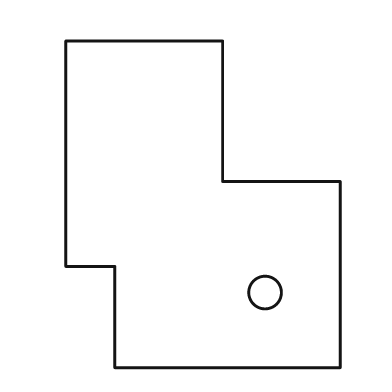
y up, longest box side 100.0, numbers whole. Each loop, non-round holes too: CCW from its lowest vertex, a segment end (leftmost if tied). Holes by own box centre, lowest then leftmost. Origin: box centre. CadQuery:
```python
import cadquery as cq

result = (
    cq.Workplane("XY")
    .moveTo(-27.0, -50.0)
    .lineTo(42.0, -50.0)
    .lineTo(42.0, 7.0)
    .lineTo(6.0, 7.0)
    .lineTo(6.0, 50.0)
    .lineTo(-42.0, 50.0)
    .lineTo(-42.0, -19.0)
    .lineTo(-27.0, -19.0)
    .close()
    .moveTo(19.0, -27.0)
    .circle(5.0)
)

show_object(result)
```